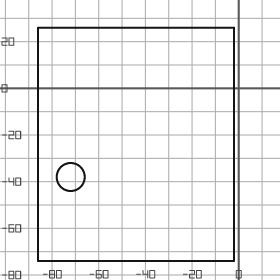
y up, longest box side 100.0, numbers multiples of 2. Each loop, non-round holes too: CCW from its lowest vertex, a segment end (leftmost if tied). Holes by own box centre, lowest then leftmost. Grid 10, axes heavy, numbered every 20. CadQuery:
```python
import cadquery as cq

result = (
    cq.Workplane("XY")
    .moveTo(-86.0, -74.0)
    .lineTo(-2.0, -74.0)
    .lineTo(-2.0, 26.0)
    .lineTo(-86.0, 26.0)
    .close()
    .moveTo(-72.0, -38.0)
    .circle(6.0)
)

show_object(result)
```